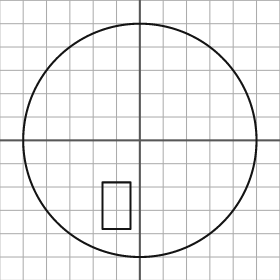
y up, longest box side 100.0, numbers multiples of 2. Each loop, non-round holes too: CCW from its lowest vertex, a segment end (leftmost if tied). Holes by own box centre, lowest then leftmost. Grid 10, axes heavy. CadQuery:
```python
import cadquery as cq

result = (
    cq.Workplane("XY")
    .moveTo(0.0, 0.0)
    .circle(50.0)
    .moveTo(-16.0, -38.0)
    .lineTo(-4.0, -38.0)
    .lineTo(-4.0, -18.0)
    .lineTo(-16.0, -18.0)
    .close()
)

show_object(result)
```